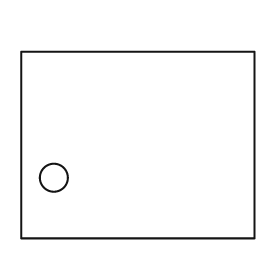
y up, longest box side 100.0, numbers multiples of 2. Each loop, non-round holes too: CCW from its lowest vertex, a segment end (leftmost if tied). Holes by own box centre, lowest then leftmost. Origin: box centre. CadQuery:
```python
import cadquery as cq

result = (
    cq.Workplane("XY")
    .moveTo(-50.0, -40.0)
    .lineTo(50.0, -40.0)
    .lineTo(50.0, 40.0)
    .lineTo(-50.0, 40.0)
    .close()
    .moveTo(-36.0, -14.0)
    .circle(6.0)
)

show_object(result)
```